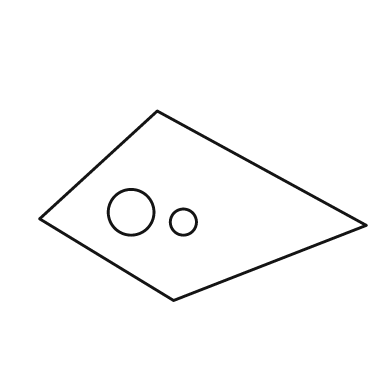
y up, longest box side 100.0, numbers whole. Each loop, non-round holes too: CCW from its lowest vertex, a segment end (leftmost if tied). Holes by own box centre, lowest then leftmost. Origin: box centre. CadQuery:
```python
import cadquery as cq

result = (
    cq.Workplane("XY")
    .moveTo(-9.0, -29.0)
    .lineTo(50.0, -6.0)
    .lineTo(-14.0, 29.0)
    .lineTo(-50.0, -4.0)
    .close()
    .moveTo(-6.0, -5.0)
    .circle(4.0)
    .moveTo(-22.0, -2.0)
    .circle(7.0)
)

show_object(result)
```